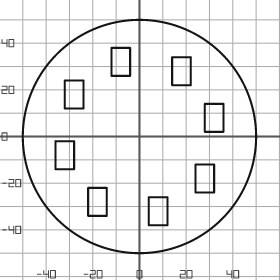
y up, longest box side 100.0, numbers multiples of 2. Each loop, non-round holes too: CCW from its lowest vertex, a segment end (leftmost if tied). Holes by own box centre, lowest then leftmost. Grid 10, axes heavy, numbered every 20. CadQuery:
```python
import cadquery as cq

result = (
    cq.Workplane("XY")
    .moveTo(0.0, 0.0)
    .circle(50.0)
    .moveTo(4.0, -38.0)
    .lineTo(12.0, -38.0)
    .lineTo(12.0, -26.0)
    .lineTo(4.0, -26.0)
    .close()
    .moveTo(-22.0, -34.0)
    .lineTo(-14.0, -34.0)
    .lineTo(-14.0, -22.0)
    .lineTo(-22.0, -22.0)
    .close()
    .moveTo(24.0, -24.0)
    .lineTo(32.0, -24.0)
    .lineTo(32.0, -12.0)
    .lineTo(24.0, -12.0)
    .close()
    .moveTo(-36.0, -14.0)
    .lineTo(-28.0, -14.0)
    .lineTo(-28.0, -2.0)
    .lineTo(-36.0, -2.0)
    .close()
    .moveTo(28.0, 2.0)
    .lineTo(36.0, 2.0)
    .lineTo(36.0, 14.0)
    .lineTo(28.0, 14.0)
    .close()
    .moveTo(-32.0, 12.0)
    .lineTo(-24.0, 12.0)
    .lineTo(-24.0, 24.0)
    .lineTo(-32.0, 24.0)
    .close()
    .moveTo(14.0, 22.0)
    .lineTo(22.0, 22.0)
    .lineTo(22.0, 34.0)
    .lineTo(14.0, 34.0)
    .close()
    .moveTo(-12.0, 26.0)
    .lineTo(-4.0, 26.0)
    .lineTo(-4.0, 38.0)
    .lineTo(-12.0, 38.0)
    .close()
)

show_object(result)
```